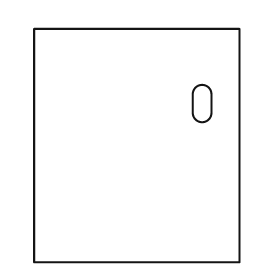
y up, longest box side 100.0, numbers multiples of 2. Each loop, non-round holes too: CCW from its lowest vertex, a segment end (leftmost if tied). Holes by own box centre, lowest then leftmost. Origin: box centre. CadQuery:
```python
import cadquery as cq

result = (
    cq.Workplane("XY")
    .moveTo(-44.0, -50.0)
    .lineTo(44.0, -50.0)
    .lineTo(44.0, 50.0)
    .lineTo(-44.0, 50.0)
    .close()
    .moveTo(24.0, 14.0)
    .threePointArc((28.0, 10.0), (32.0, 14.0))
    .lineTo(32.0, 22.0)
    .threePointArc((28.0, 26.0), (24.0, 22.0))
    .close()
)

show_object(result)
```